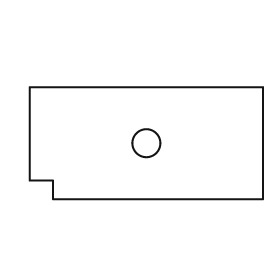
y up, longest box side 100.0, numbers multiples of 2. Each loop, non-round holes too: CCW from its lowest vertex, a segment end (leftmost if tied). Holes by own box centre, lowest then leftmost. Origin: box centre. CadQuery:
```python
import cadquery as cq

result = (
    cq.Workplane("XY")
    .moveTo(-40.0, -24.0)
    .lineTo(50.0, -24.0)
    .lineTo(50.0, 24.0)
    .lineTo(-50.0, 24.0)
    .lineTo(-50.0, -16.0)
    .lineTo(-40.0, -16.0)
    .close()
    .moveTo(0.0, 0.0)
    .circle(6.0)
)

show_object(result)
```